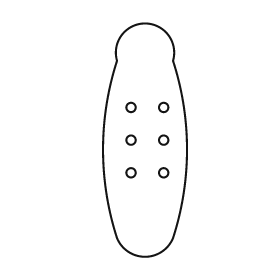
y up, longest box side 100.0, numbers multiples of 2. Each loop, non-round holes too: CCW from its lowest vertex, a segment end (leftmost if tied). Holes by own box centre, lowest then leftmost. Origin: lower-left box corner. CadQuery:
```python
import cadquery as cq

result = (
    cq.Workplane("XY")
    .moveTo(6.0, 8.0)
    .threePointArc((18.0, 0.0), (30.0, 8.0))
    .threePointArc((36.0, 46.0), (30.0, 84.0))
    .threePointArc((18.0, 100.0), (6.0, 84.0))
    .threePointArc((0.0, 46.0), (6.0, 8.0))
    .close()
    .moveTo(12.0, 36.0)
    .circle(2.0)
    .moveTo(26.0, 36.0)
    .circle(2.0)
    .moveTo(12.0, 50.0)
    .circle(2.0)
    .moveTo(26.0, 50.0)
    .circle(2.0)
    .moveTo(12.0, 64.0)
    .circle(2.0)
    .moveTo(26.0, 64.0)
    .circle(2.0)
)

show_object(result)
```